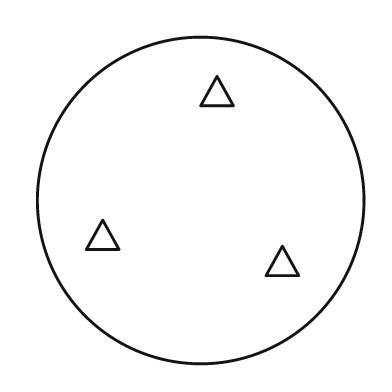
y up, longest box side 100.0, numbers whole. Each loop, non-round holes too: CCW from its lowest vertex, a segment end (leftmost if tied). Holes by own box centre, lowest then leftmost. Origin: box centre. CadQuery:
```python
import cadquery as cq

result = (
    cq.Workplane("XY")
    .moveTo(0.0, 0.0)
    .circle(50.0)
    .moveTo(20.0, -23.0)
    .lineTo(30.0, -23.0)
    .lineTo(25.0, -14.0)
    .close()
    .moveTo(-35.0, -15.0)
    .lineTo(-25.0, -15.0)
    .lineTo(-30.0, -6.0)
    .close()
    .moveTo(0.0, 29.0)
    .lineTo(10.0, 29.0)
    .lineTo(5.0, 38.0)
    .close()
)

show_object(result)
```